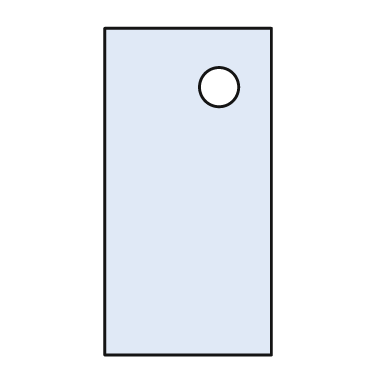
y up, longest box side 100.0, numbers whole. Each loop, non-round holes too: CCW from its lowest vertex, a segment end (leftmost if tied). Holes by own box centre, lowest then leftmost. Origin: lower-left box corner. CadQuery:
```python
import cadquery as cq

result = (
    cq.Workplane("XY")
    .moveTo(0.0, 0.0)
    .lineTo(51.0, 0.0)
    .lineTo(51.0, 100.0)
    .lineTo(0.0, 100.0)
    .close()
    .moveTo(35.0, 82.0)
    .circle(6.0)
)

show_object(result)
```